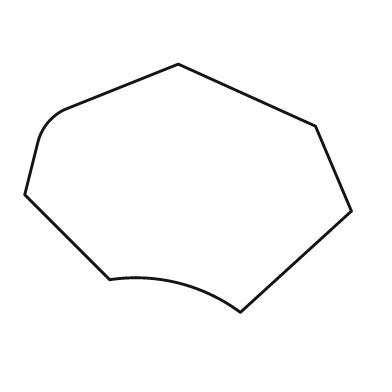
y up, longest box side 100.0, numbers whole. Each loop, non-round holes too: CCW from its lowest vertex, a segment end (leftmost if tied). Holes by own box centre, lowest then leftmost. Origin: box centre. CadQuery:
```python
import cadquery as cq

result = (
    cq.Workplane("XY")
    .moveTo(16.0, -38.0)
    .lineTo(50.0, -7.0)
    .lineTo(39.0, 19.0)
    .lineTo(-3.0, 38.0)
    .lineTo(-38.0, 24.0)
    .threePointArc((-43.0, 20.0), (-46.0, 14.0))
    .lineTo(-50.0, -2.0)
    .lineTo(-24.0, -28.0)
    .threePointArc((-3.0, -29.0), (16.0, -38.0))
    .close()
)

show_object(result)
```